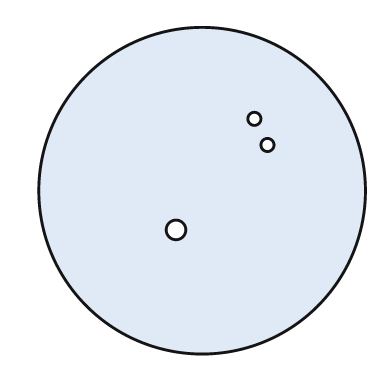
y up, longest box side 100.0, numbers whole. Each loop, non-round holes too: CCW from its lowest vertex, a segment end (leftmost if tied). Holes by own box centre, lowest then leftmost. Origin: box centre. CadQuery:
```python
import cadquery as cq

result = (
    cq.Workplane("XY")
    .moveTo(0.0, 0.0)
    .circle(50.0)
    .moveTo(-8.0, -12.0)
    .circle(3.0)
    .moveTo(20.0, 14.0)
    .circle(2.0)
    .moveTo(16.0, 22.0)
    .circle(2.0)
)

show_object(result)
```